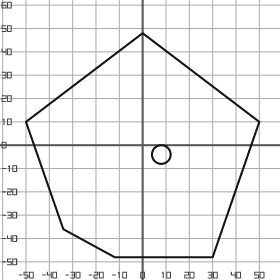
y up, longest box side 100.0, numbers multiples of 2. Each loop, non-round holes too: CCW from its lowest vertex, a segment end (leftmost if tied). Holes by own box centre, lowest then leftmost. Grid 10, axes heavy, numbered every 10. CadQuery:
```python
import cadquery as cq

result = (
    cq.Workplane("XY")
    .moveTo(-12.0, -48.0)
    .lineTo(30.0, -48.0)
    .lineTo(50.0, 10.0)
    .lineTo(0.0, 48.0)
    .lineTo(-50.0, 10.0)
    .lineTo(-34.0, -36.0)
    .close()
    .moveTo(8.0, -4.0)
    .circle(4.0)
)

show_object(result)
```